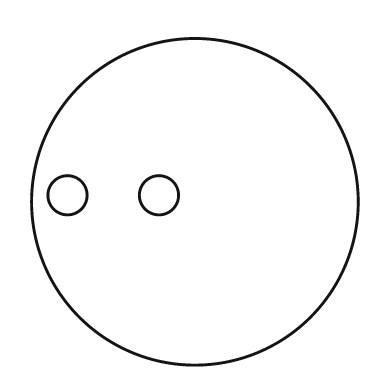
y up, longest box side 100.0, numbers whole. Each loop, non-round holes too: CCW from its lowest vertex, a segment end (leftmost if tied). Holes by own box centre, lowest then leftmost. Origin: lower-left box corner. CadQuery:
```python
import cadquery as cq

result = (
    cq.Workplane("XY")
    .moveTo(50.0, 50.0)
    .circle(50.0)
    .moveTo(11.0, 52.0)
    .circle(6.0)
    .moveTo(39.0, 52.0)
    .circle(6.0)
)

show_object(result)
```